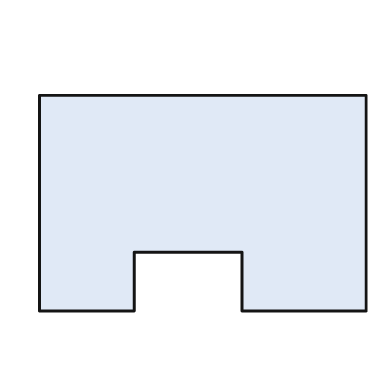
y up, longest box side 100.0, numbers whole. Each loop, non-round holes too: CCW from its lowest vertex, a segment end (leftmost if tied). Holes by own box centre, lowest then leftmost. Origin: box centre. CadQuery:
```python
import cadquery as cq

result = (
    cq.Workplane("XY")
    .moveTo(-50.0, -33.0)
    .lineTo(-21.0, -33.0)
    .lineTo(-21.0, -15.0)
    .lineTo(12.0, -15.0)
    .lineTo(12.0, -33.0)
    .lineTo(50.0, -33.0)
    .lineTo(50.0, 33.0)
    .lineTo(-50.0, 33.0)
    .close()
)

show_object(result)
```